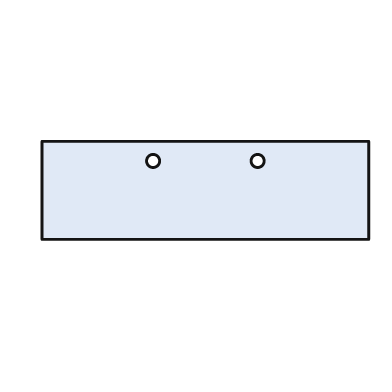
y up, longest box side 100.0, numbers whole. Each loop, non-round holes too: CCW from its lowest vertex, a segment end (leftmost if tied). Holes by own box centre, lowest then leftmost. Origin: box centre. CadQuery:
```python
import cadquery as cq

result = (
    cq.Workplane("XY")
    .moveTo(-50.0, -15.0)
    .lineTo(50.0, -15.0)
    .lineTo(50.0, 15.0)
    .lineTo(-50.0, 15.0)
    .close()
    .moveTo(-16.0, 9.0)
    .circle(2.0)
    .moveTo(16.0, 9.0)
    .circle(2.0)
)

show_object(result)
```